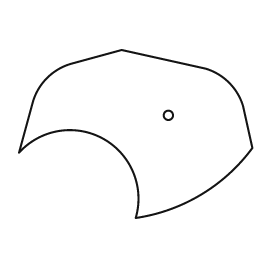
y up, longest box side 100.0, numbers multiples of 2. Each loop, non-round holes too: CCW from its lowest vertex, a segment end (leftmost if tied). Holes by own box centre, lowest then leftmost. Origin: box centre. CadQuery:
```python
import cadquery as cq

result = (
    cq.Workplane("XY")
    .moveTo(0.0, -36.0)
    .threePointArc((28.0, -26.0), (50.0, -6.0))
    .lineTo(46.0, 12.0)
    .threePointArc((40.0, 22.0), (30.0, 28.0))
    .lineTo(-6.0, 36.0)
    .lineTo(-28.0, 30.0)
    .threePointArc((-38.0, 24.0), (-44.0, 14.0))
    .lineTo(-50.0, -8.0)
    .threePointArc((-14.0, -2.0), (0.0, -36.0))
    .close()
    .moveTo(14.0, 8.0)
    .circle(2.0)
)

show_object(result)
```